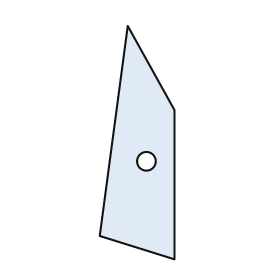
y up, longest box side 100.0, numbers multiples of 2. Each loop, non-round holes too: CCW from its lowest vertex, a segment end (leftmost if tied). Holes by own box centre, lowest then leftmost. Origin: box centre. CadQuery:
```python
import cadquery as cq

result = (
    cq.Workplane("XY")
    .moveTo(16.0, -50.0)
    .lineTo(16.0, 14.0)
    .lineTo(-4.0, 50.0)
    .lineTo(-16.0, -40.0)
    .close()
    .moveTo(4.0, -8.0)
    .circle(4.0)
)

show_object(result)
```